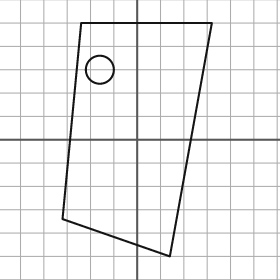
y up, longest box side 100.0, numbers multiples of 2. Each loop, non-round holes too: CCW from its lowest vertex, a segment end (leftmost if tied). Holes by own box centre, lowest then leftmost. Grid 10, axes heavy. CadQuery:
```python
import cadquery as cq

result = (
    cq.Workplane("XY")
    .moveTo(14.0, -50.0)
    .lineTo(32.0, 50.0)
    .lineTo(-24.0, 50.0)
    .lineTo(-32.0, -34.0)
    .close()
    .moveTo(-16.0, 30.0)
    .circle(6.0)
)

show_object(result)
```